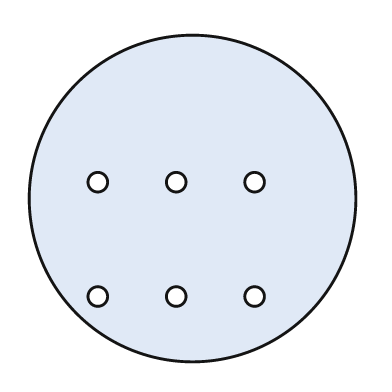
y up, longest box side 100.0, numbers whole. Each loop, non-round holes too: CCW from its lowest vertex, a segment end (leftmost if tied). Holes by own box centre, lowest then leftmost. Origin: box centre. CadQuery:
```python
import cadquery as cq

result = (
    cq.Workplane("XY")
    .moveTo(0.0, 0.0)
    .circle(50.0)
    .moveTo(-29.0, -30.0)
    .circle(3.0)
    .moveTo(-5.0, -30.0)
    .circle(3.0)
    .moveTo(19.0, -30.0)
    .circle(3.0)
    .moveTo(-29.0, 5.0)
    .circle(3.0)
    .moveTo(-5.0, 5.0)
    .circle(3.0)
    .moveTo(19.0, 5.0)
    .circle(3.0)
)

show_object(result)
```